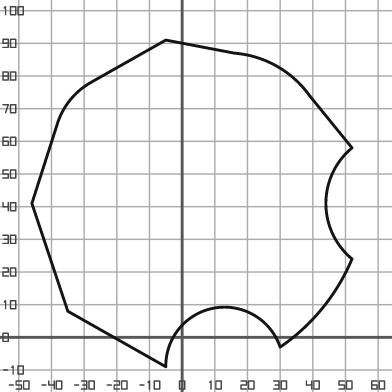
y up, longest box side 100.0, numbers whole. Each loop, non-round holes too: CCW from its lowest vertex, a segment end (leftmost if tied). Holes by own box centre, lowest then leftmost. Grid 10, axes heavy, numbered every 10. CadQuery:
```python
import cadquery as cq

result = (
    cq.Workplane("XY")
    .moveTo(-5.0, -9.0)
    .threePointArc((10.0, 9.0), (30.0, -3.0))
    .threePointArc((43.0, 9.0), (52.0, 24.0))
    .threePointArc((44.0, 41.0), (52.0, 58.0))
    .lineTo(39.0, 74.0)
    .threePointArc((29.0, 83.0), (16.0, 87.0))
    .lineTo(-5.0, 91.0)
    .lineTo(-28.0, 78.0)
    .threePointArc((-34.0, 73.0), (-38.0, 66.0))
    .lineTo(-46.0, 41.0)
    .lineTo(-35.0, 8.0)
    .close()
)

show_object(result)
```